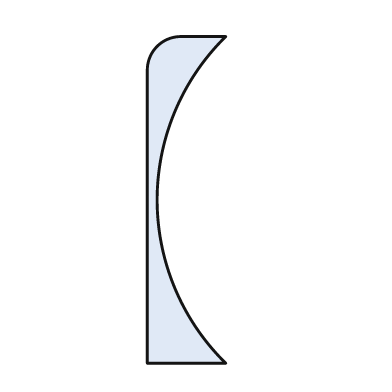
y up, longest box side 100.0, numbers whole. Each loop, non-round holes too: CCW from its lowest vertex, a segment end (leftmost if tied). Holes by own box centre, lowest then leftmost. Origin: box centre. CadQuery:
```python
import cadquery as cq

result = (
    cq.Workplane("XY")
    .moveTo(-12.0, -50.0)
    .lineTo(12.0, -50.0)
    .threePointArc((-9.0, 0.0), (12.0, 50.0))
    .lineTo(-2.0, 50.0)
    .threePointArc((-9.0, 47.0), (-12.0, 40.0))
    .close()
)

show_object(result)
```